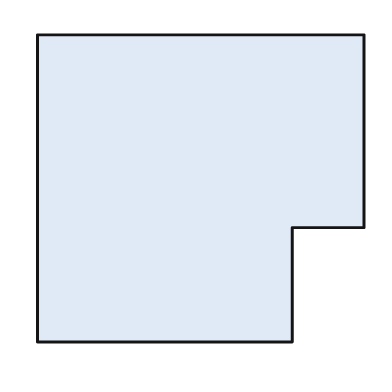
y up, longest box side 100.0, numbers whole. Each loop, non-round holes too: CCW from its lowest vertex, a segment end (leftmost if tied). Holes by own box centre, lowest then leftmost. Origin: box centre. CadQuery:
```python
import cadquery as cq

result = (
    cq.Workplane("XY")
    .moveTo(-50.0, -47.0)
    .lineTo(28.0, -47.0)
    .lineTo(28.0, -12.0)
    .lineTo(50.0, -12.0)
    .lineTo(50.0, 47.0)
    .lineTo(-50.0, 47.0)
    .close()
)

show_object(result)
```